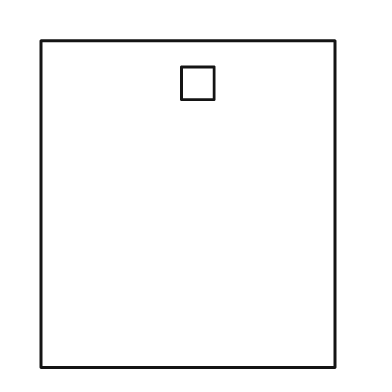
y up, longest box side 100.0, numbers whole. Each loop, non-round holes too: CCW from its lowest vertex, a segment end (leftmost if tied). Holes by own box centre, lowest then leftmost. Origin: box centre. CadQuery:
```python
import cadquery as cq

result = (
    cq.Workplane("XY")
    .moveTo(-45.0, -50.0)
    .lineTo(45.0, -50.0)
    .lineTo(45.0, 50.0)
    .lineTo(-45.0, 50.0)
    .close()
    .moveTo(-2.0, 32.0)
    .lineTo(8.0, 32.0)
    .lineTo(8.0, 42.0)
    .lineTo(-2.0, 42.0)
    .close()
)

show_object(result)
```